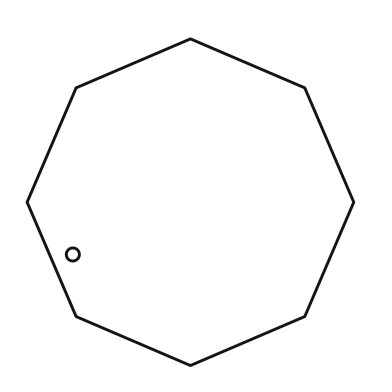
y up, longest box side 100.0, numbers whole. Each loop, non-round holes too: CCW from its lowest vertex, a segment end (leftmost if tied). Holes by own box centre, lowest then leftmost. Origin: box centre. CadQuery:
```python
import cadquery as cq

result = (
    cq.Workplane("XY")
    .moveTo(0.0, -50.0)
    .lineTo(35.0, -35.0)
    .lineTo(50.0, 0.0)
    .lineTo(35.0, 35.0)
    .lineTo(0.0, 50.0)
    .lineTo(-35.0, 35.0)
    .lineTo(-50.0, 0.0)
    .lineTo(-35.0, -35.0)
    .close()
    .moveTo(-36.0, -16.0)
    .circle(2.0)
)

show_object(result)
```